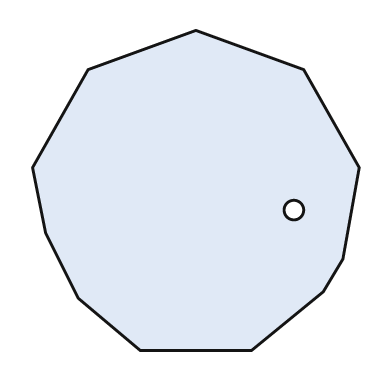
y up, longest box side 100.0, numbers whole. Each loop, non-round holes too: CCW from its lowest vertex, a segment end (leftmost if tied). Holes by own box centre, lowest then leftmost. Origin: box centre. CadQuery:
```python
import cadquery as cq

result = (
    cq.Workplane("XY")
    .moveTo(-17.0, -49.0)
    .lineTo(17.0, -49.0)
    .lineTo(39.0, -31.0)
    .lineTo(45.0, -21.0)
    .lineTo(50.0, 7.0)
    .lineTo(33.0, 37.0)
    .lineTo(0.0, 49.0)
    .lineTo(-33.0, 37.0)
    .lineTo(-50.0, 7.0)
    .lineTo(-46.0, -13.0)
    .lineTo(-36.0, -33.0)
    .close()
    .moveTo(30.0, -6.0)
    .circle(3.0)
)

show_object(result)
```